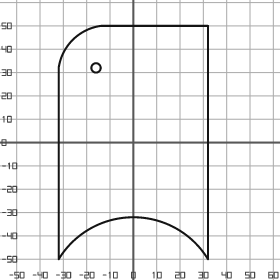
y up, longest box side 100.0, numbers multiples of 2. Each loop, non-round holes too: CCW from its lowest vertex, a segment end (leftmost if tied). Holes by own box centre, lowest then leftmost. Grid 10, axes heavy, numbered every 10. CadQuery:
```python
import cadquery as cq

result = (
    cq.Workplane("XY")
    .moveTo(-32.0, -50.0)
    .threePointArc((0.0, -32.0), (32.0, -50.0))
    .lineTo(32.0, 50.0)
    .lineTo(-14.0, 50.0)
    .threePointArc((-26.0, 44.0), (-32.0, 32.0))
    .close()
    .moveTo(-16.0, 32.0)
    .circle(2.0)
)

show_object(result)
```